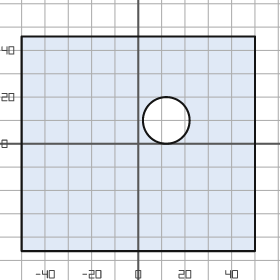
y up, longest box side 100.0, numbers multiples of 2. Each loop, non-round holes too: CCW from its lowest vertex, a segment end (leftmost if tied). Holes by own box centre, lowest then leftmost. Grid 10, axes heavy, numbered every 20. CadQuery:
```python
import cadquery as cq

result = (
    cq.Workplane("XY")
    .moveTo(-50.0, -46.0)
    .lineTo(50.0, -46.0)
    .lineTo(50.0, 46.0)
    .lineTo(-50.0, 46.0)
    .close()
    .moveTo(12.0, 10.0)
    .circle(10.0)
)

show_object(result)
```